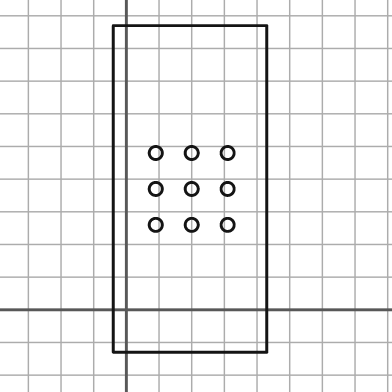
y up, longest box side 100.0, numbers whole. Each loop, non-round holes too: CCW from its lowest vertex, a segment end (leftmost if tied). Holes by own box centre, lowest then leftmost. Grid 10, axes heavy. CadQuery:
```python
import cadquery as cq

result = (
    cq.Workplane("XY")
    .moveTo(-4.0, -13.0)
    .lineTo(43.0, -13.0)
    .lineTo(43.0, 87.0)
    .lineTo(-4.0, 87.0)
    .close()
    .moveTo(9.0, 26.0)
    .circle(2.0)
    .moveTo(20.0, 26.0)
    .circle(2.0)
    .moveTo(31.0, 26.0)
    .circle(2.0)
    .moveTo(9.0, 37.0)
    .circle(2.0)
    .moveTo(20.0, 37.0)
    .circle(2.0)
    .moveTo(31.0, 37.0)
    .circle(2.0)
    .moveTo(9.0, 48.0)
    .circle(2.0)
    .moveTo(20.0, 48.0)
    .circle(2.0)
    .moveTo(31.0, 48.0)
    .circle(2.0)
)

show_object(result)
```